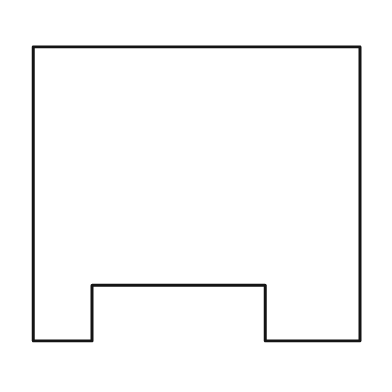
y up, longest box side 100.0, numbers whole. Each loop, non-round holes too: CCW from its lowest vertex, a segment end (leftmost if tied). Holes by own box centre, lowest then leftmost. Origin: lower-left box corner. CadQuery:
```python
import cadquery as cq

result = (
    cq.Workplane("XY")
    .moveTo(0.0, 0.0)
    .lineTo(18.0, 0.0)
    .lineTo(18.0, 17.0)
    .lineTo(71.0, 17.0)
    .lineTo(71.0, 0.0)
    .lineTo(100.0, 0.0)
    .lineTo(100.0, 90.0)
    .lineTo(0.0, 90.0)
    .close()
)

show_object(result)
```